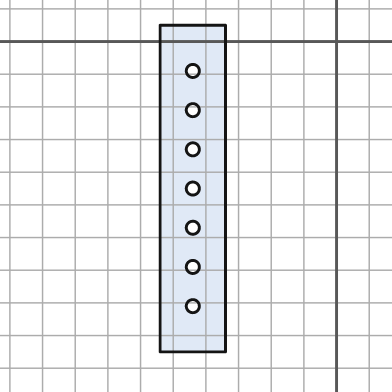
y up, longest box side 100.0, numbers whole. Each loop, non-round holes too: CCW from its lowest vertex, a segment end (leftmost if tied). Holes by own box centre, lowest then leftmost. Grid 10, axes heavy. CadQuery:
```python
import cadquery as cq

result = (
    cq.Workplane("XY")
    .moveTo(-54.0, -95.0)
    .lineTo(-34.0, -95.0)
    .lineTo(-34.0, 5.0)
    .lineTo(-54.0, 5.0)
    .close()
    .moveTo(-44.0, -81.0)
    .circle(2.0)
    .moveTo(-44.0, -69.0)
    .circle(2.0)
    .moveTo(-44.0, -57.0)
    .circle(2.0)
    .moveTo(-44.0, -45.0)
    .circle(2.0)
    .moveTo(-44.0, -33.0)
    .circle(2.0)
    .moveTo(-44.0, -21.0)
    .circle(2.0)
    .moveTo(-44.0, -9.0)
    .circle(2.0)
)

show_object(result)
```